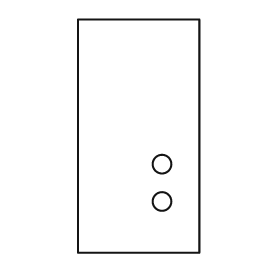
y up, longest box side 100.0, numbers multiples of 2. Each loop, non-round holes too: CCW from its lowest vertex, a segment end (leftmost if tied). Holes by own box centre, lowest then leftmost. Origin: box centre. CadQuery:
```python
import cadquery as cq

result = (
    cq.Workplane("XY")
    .moveTo(-26.0, -50.0)
    .lineTo(26.0, -50.0)
    .lineTo(26.0, 50.0)
    .lineTo(-26.0, 50.0)
    .close()
    .moveTo(10.0, -28.0)
    .circle(4.0)
    .moveTo(10.0, -12.0)
    .circle(4.0)
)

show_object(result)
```